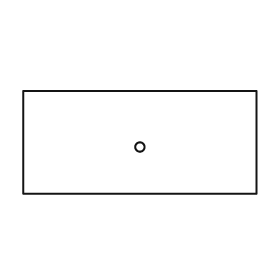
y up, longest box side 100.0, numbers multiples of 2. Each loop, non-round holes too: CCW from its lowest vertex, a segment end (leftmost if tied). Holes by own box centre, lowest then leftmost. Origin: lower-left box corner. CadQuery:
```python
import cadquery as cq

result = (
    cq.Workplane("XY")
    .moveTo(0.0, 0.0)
    .lineTo(100.0, 0.0)
    .lineTo(100.0, 44.0)
    .lineTo(0.0, 44.0)
    .close()
    .moveTo(50.0, 20.0)
    .circle(2.0)
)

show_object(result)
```